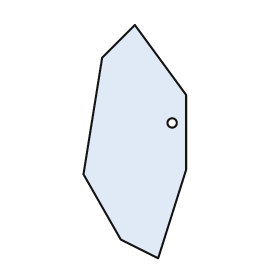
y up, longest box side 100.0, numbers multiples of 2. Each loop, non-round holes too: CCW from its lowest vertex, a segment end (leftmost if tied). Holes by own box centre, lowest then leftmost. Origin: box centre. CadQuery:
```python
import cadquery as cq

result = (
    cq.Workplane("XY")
    .moveTo(10.0, -50.0)
    .lineTo(22.0, -12.0)
    .lineTo(22.0, 20.0)
    .lineTo(0.0, 50.0)
    .lineTo(-14.0, 36.0)
    .lineTo(-22.0, -14.0)
    .lineTo(-6.0, -42.0)
    .close()
    .moveTo(16.0, 8.0)
    .circle(2.0)
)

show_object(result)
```